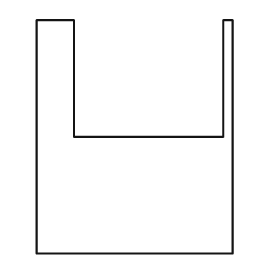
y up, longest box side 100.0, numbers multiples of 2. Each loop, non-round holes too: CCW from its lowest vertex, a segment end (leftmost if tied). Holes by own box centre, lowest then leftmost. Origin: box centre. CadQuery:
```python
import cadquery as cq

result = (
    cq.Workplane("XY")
    .moveTo(-42.0, -50.0)
    .lineTo(42.0, -50.0)
    .lineTo(42.0, 50.0)
    .lineTo(38.0, 50.0)
    .lineTo(38.0, 0.0)
    .lineTo(-26.0, 0.0)
    .lineTo(-26.0, 50.0)
    .lineTo(-42.0, 50.0)
    .close()
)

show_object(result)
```